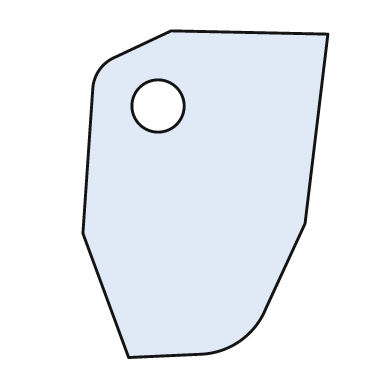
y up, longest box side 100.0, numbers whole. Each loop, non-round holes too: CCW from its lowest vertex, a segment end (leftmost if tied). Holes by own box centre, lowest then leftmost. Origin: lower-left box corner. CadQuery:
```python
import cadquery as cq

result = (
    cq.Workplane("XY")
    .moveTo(14.0, 0.0)
    .lineTo(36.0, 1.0)
    .threePointArc((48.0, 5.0), (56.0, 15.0))
    .lineTo(68.0, 41.0)
    .lineTo(75.0, 99.0)
    .lineTo(27.0, 100.0)
    .lineTo(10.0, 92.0)
    .threePointArc((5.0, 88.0), (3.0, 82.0))
    .lineTo(0.0, 38.0)
    .close()
    .moveTo(23.0, 77.0)
    .circle(8.0)
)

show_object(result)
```